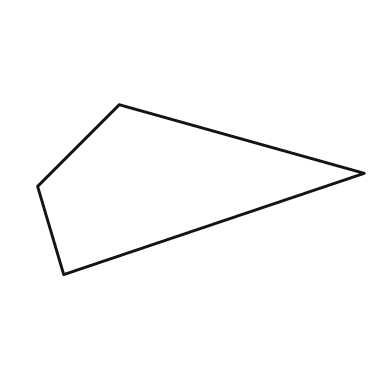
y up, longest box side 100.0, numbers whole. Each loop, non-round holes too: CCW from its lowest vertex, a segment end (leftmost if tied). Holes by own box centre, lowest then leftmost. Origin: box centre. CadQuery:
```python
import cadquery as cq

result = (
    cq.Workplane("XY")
    .moveTo(-42.0, -26.0)
    .lineTo(50.0, 5.0)
    .lineTo(-25.0, 26.0)
    .lineTo(-50.0, 1.0)
    .close()
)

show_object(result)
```